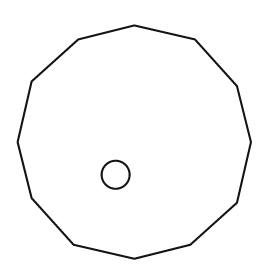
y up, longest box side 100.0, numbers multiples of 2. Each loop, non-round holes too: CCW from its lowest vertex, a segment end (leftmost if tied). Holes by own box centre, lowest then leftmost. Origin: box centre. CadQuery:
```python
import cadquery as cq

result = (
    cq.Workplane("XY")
    .moveTo(0.0, -50.0)
    .lineTo(24.0, -44.0)
    .lineTo(44.0, -26.0)
    .lineTo(50.0, 0.0)
    .lineTo(44.0, 24.0)
    .lineTo(26.0, 44.0)
    .lineTo(0.0, 50.0)
    .lineTo(-24.0, 44.0)
    .lineTo(-44.0, 26.0)
    .lineTo(-50.0, 0.0)
    .lineTo(-44.0, -24.0)
    .lineTo(-26.0, -44.0)
    .close()
    .moveTo(-8.0, -14.0)
    .circle(6.0)
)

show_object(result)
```